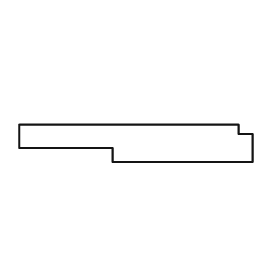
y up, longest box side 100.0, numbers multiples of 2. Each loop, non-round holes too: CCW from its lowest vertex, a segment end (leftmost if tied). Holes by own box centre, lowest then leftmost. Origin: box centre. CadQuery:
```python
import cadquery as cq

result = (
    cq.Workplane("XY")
    .moveTo(-10.0, -8.0)
    .lineTo(50.0, -8.0)
    .lineTo(50.0, 4.0)
    .lineTo(44.0, 4.0)
    .lineTo(44.0, 8.0)
    .lineTo(-50.0, 8.0)
    .lineTo(-50.0, -2.0)
    .lineTo(-10.0, -2.0)
    .close()
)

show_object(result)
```